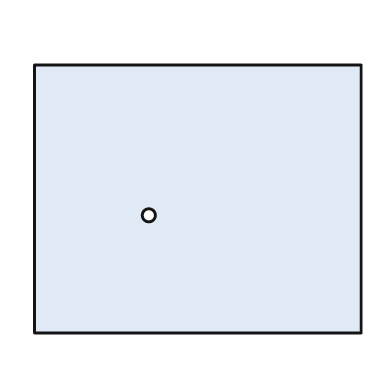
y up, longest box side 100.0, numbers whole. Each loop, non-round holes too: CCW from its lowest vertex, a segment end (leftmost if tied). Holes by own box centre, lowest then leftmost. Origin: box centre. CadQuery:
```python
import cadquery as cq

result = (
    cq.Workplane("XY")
    .moveTo(-50.0, -41.0)
    .lineTo(50.0, -41.0)
    .lineTo(50.0, 41.0)
    .lineTo(-50.0, 41.0)
    .close()
    .moveTo(-15.0, -5.0)
    .circle(2.0)
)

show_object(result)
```